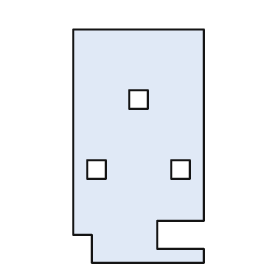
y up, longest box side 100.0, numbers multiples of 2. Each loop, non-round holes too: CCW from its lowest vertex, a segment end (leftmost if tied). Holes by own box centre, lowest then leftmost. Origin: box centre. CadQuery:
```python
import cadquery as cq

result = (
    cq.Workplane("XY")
    .moveTo(-20.0, -50.0)
    .lineTo(28.0, -50.0)
    .lineTo(28.0, -44.0)
    .lineTo(8.0, -44.0)
    .lineTo(8.0, -32.0)
    .lineTo(28.0, -32.0)
    .lineTo(28.0, 50.0)
    .lineTo(-28.0, 50.0)
    .lineTo(-28.0, -38.0)
    .lineTo(-20.0, -38.0)
    .close()
    .moveTo(-22.0, -14.0)
    .lineTo(-14.0, -14.0)
    .lineTo(-14.0, -6.0)
    .lineTo(-22.0, -6.0)
    .close()
    .moveTo(14.0, -14.0)
    .lineTo(22.0, -14.0)
    .lineTo(22.0, -6.0)
    .lineTo(14.0, -6.0)
    .close()
    .moveTo(-4.0, 16.0)
    .lineTo(4.0, 16.0)
    .lineTo(4.0, 24.0)
    .lineTo(-4.0, 24.0)
    .close()
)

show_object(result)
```